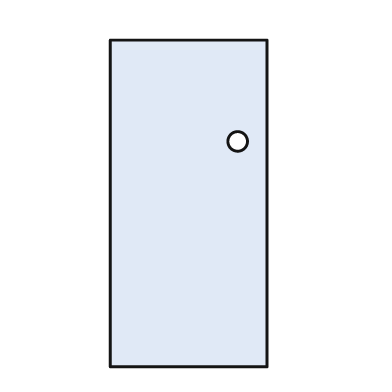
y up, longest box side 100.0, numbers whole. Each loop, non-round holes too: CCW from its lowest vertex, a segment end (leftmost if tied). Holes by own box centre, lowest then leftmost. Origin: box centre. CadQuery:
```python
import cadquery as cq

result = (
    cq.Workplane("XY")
    .moveTo(-24.0, -50.0)
    .lineTo(24.0, -50.0)
    .lineTo(24.0, 50.0)
    .lineTo(-24.0, 50.0)
    .close()
    .moveTo(15.0, 19.0)
    .circle(3.0)
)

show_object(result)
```